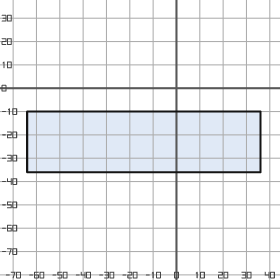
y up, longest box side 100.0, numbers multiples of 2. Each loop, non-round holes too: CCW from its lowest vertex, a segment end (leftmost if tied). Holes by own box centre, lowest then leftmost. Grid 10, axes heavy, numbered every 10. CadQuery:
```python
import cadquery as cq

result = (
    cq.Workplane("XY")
    .moveTo(-64.0, -36.0)
    .lineTo(36.0, -36.0)
    .lineTo(36.0, -10.0)
    .lineTo(-64.0, -10.0)
    .close()
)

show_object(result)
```